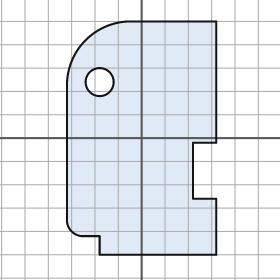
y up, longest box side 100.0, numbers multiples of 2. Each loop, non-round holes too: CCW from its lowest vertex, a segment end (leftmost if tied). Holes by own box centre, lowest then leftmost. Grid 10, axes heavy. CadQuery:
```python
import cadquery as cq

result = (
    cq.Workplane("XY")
    .moveTo(-18.0, -50.0)
    .lineTo(32.0, -50.0)
    .lineTo(32.0, -26.0)
    .lineTo(22.0, -26.0)
    .lineTo(22.0, -2.0)
    .lineTo(32.0, -2.0)
    .lineTo(32.0, 50.0)
    .lineTo(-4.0, 50.0)
    .threePointArc((-24.0, 42.0), (-32.0, 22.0))
    .lineTo(-32.0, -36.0)
    .threePointArc((-30.0, -40.0), (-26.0, -42.0))
    .lineTo(-18.0, -42.0)
    .close()
    .moveTo(-18.0, 24.0)
    .circle(6.0)
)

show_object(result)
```